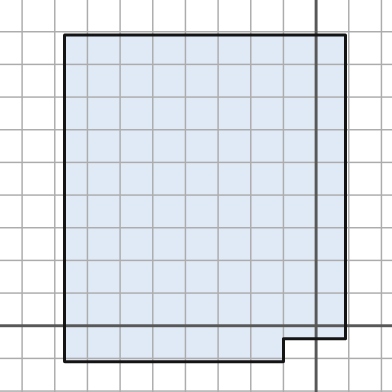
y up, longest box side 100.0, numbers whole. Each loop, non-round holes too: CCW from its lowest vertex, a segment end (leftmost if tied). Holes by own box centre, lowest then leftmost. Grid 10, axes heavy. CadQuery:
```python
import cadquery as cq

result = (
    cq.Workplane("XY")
    .moveTo(-77.0, -11.0)
    .lineTo(-10.0, -11.0)
    .lineTo(-10.0, -4.0)
    .lineTo(9.0, -4.0)
    .lineTo(9.0, 89.0)
    .lineTo(-77.0, 89.0)
    .close()
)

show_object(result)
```